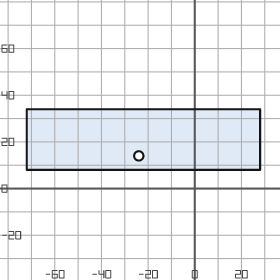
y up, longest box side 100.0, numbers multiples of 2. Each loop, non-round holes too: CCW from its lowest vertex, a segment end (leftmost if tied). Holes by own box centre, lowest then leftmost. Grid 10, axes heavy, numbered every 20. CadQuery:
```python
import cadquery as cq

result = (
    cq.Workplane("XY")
    .moveTo(-72.0, 8.0)
    .lineTo(28.0, 8.0)
    .lineTo(28.0, 34.0)
    .lineTo(-72.0, 34.0)
    .close()
    .moveTo(-24.0, 14.0)
    .circle(2.0)
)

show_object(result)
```